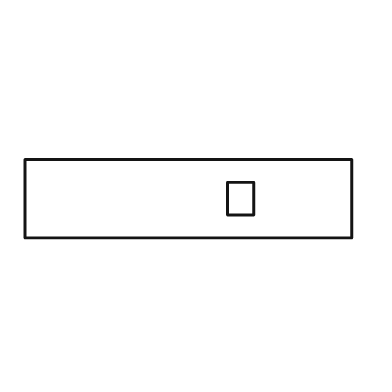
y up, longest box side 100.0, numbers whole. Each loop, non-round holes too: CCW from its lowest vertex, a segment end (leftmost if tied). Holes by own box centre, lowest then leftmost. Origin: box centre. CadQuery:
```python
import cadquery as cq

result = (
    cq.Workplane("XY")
    .moveTo(-50.0, -12.0)
    .lineTo(50.0, -12.0)
    .lineTo(50.0, 12.0)
    .lineTo(-50.0, 12.0)
    .close()
    .moveTo(12.0, -5.0)
    .lineTo(20.0, -5.0)
    .lineTo(20.0, 5.0)
    .lineTo(12.0, 5.0)
    .close()
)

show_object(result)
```